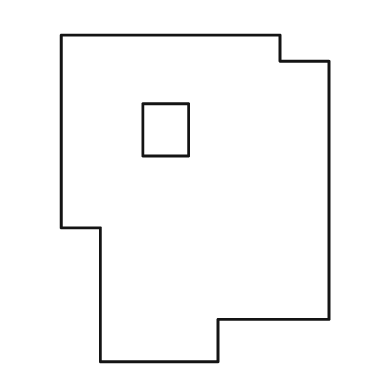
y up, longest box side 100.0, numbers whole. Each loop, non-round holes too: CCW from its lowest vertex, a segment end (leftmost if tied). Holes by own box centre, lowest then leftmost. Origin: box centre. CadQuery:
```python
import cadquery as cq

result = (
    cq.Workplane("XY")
    .moveTo(-29.0, -50.0)
    .lineTo(7.0, -50.0)
    .lineTo(7.0, -37.0)
    .lineTo(41.0, -37.0)
    .lineTo(41.0, 42.0)
    .lineTo(26.0, 42.0)
    .lineTo(26.0, 50.0)
    .lineTo(-41.0, 50.0)
    .lineTo(-41.0, -9.0)
    .lineTo(-29.0, -9.0)
    .close()
    .moveTo(-16.0, 13.0)
    .lineTo(-2.0, 13.0)
    .lineTo(-2.0, 29.0)
    .lineTo(-16.0, 29.0)
    .close()
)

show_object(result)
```